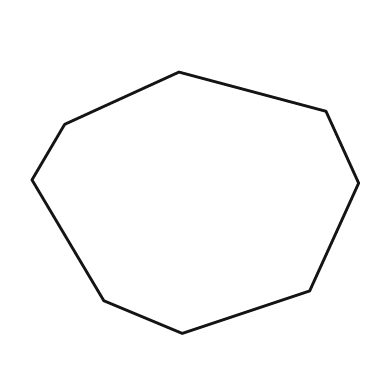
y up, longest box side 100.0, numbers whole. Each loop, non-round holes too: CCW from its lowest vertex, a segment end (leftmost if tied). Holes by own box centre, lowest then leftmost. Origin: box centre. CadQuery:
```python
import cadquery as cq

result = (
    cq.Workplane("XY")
    .moveTo(-4.0, -40.0)
    .lineTo(35.0, -27.0)
    .lineTo(50.0, 6.0)
    .lineTo(40.0, 28.0)
    .lineTo(-5.0, 40.0)
    .lineTo(-40.0, 24.0)
    .lineTo(-50.0, 7.0)
    .lineTo(-28.0, -30.0)
    .close()
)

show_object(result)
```